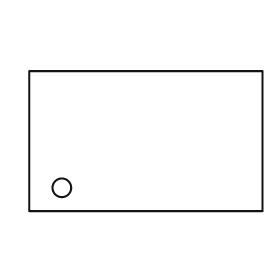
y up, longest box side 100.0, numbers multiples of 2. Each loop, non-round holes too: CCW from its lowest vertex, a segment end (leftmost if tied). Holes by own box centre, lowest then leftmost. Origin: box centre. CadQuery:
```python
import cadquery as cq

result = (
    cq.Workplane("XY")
    .moveTo(-50.0, -30.0)
    .lineTo(50.0, -30.0)
    .lineTo(50.0, 30.0)
    .lineTo(-50.0, 30.0)
    .close()
    .moveTo(-36.0, -20.0)
    .circle(4.0)
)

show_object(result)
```